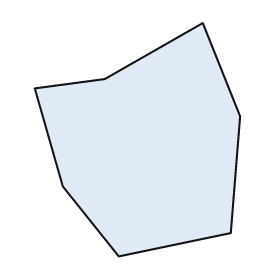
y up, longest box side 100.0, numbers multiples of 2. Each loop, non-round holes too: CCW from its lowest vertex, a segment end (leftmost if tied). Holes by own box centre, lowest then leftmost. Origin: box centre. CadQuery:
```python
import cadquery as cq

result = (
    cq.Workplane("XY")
    .moveTo(-8.0, -50.0)
    .lineTo(40.0, -40.0)
    .lineTo(44.0, 10.0)
    .lineTo(28.0, 50.0)
    .lineTo(-14.0, 26.0)
    .lineTo(-44.0, 22.0)
    .lineTo(-32.0, -20.0)
    .close()
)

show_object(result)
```